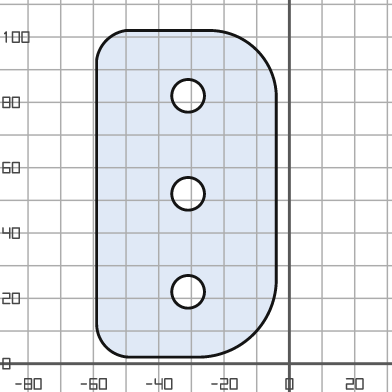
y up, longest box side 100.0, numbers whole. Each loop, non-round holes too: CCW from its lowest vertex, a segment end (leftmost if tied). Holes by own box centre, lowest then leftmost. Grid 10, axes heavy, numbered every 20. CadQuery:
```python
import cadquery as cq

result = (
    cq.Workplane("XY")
    .moveTo(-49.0, 2.0)
    .lineTo(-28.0, 2.0)
    .threePointArc((-11.0, 9.0), (-4.0, 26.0))
    .lineTo(-4.0, 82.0)
    .threePointArc((-10.0, 96.0), (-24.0, 102.0))
    .lineTo(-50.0, 102.0)
    .threePointArc((-56.0, 99.0), (-59.0, 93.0))
    .lineTo(-59.0, 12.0)
    .threePointArc((-56.0, 5.0), (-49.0, 2.0))
    .close()
    .moveTo(-31.0, 22.0)
    .circle(5.0)
    .moveTo(-31.0, 52.0)
    .circle(5.0)
    .moveTo(-31.0, 82.0)
    .circle(5.0)
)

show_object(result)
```